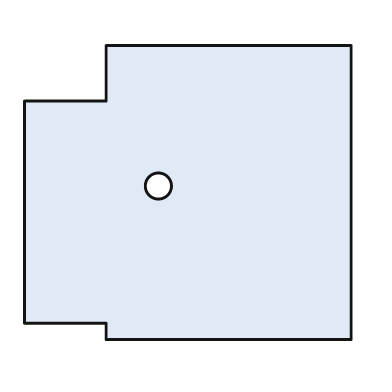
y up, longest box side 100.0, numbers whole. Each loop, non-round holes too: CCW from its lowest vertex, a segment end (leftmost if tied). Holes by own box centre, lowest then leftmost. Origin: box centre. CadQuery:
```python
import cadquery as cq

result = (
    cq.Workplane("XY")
    .moveTo(-25.0, -45.0)
    .lineTo(50.0, -45.0)
    .lineTo(50.0, 45.0)
    .lineTo(-25.0, 45.0)
    .lineTo(-25.0, 28.0)
    .lineTo(-50.0, 28.0)
    .lineTo(-50.0, -40.0)
    .lineTo(-25.0, -40.0)
    .close()
    .moveTo(-9.0, 2.0)
    .circle(4.0)
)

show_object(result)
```